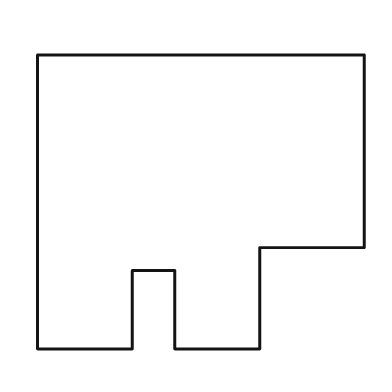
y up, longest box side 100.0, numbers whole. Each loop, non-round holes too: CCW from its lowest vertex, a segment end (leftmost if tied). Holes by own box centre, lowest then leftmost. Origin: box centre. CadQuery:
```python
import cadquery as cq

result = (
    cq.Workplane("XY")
    .moveTo(-50.0, -45.0)
    .lineTo(-21.0, -45.0)
    .lineTo(-21.0, -21.0)
    .lineTo(-8.0, -21.0)
    .lineTo(-8.0, -45.0)
    .lineTo(18.0, -45.0)
    .lineTo(18.0, -14.0)
    .lineTo(50.0, -14.0)
    .lineTo(50.0, 45.0)
    .lineTo(-50.0, 45.0)
    .close()
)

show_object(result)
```